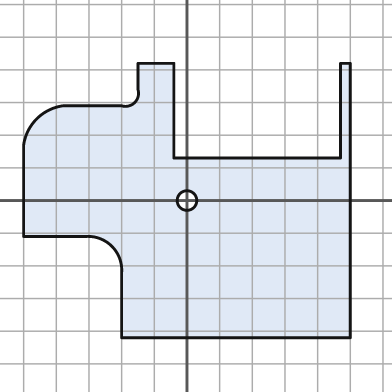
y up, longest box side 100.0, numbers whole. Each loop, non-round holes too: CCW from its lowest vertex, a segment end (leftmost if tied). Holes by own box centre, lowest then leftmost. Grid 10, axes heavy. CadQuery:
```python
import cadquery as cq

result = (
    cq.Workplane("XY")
    .moveTo(-20.0, -42.0)
    .lineTo(50.0, -42.0)
    .lineTo(50.0, 42.0)
    .lineTo(47.0, 42.0)
    .lineTo(47.0, 13.0)
    .lineTo(-4.0, 13.0)
    .lineTo(-4.0, 42.0)
    .lineTo(-15.0, 42.0)
    .lineTo(-15.0, 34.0)
    .threePointArc((-16.0, 30.0), (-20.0, 29.0))
    .lineTo(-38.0, 29.0)
    .threePointArc((-46.0, 25.0), (-50.0, 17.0))
    .lineTo(-50.0, -11.0)
    .lineTo(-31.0, -11.0)
    .threePointArc((-23.0, -14.0), (-20.0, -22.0))
    .close()
    .moveTo(0.0, 0.0)
    .circle(3.0)
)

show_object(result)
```